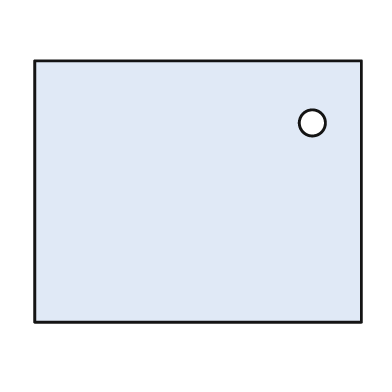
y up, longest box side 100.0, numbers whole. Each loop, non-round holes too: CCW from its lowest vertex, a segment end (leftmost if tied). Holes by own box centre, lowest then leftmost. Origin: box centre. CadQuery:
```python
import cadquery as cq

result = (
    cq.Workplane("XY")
    .moveTo(-50.0, -40.0)
    .lineTo(50.0, -40.0)
    .lineTo(50.0, 40.0)
    .lineTo(-50.0, 40.0)
    .close()
    .moveTo(35.0, 21.0)
    .circle(4.0)
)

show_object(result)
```